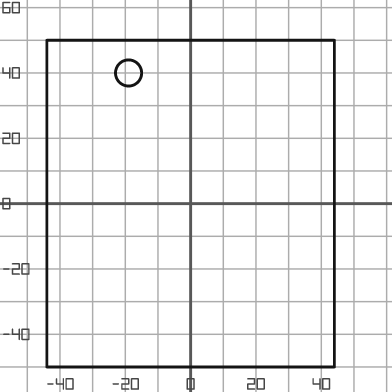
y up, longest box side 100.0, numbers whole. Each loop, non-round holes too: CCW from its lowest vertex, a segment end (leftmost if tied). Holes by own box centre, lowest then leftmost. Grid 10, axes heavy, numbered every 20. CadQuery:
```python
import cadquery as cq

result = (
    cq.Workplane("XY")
    .moveTo(-44.0, -50.0)
    .lineTo(44.0, -50.0)
    .lineTo(44.0, 50.0)
    .lineTo(-44.0, 50.0)
    .close()
    .moveTo(-19.0, 40.0)
    .circle(4.0)
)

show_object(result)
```